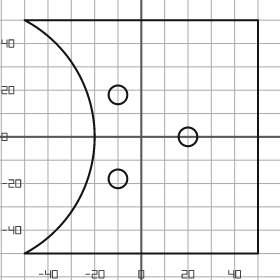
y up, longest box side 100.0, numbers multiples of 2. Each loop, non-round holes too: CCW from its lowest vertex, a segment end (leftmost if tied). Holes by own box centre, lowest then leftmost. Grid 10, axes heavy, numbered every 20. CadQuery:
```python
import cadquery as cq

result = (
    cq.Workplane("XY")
    .moveTo(-50.0, -50.0)
    .lineTo(50.0, -50.0)
    .lineTo(50.0, 50.0)
    .lineTo(-50.0, 50.0)
    .threePointArc((-20.0, 0.0), (-50.0, -50.0))
    .close()
    .moveTo(-10.0, -18.0)
    .circle(4.0)
    .moveTo(20.0, 0.0)
    .circle(4.0)
    .moveTo(-10.0, 18.0)
    .circle(4.0)
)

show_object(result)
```